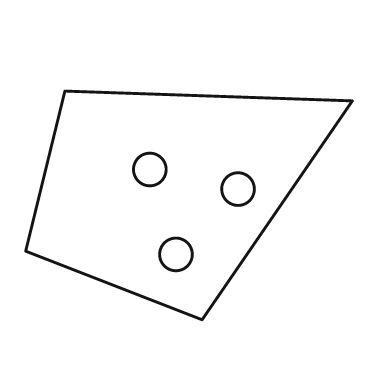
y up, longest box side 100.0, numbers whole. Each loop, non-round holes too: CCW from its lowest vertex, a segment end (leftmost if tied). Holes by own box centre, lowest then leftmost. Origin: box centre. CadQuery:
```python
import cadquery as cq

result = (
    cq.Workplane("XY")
    .moveTo(4.0, -35.0)
    .lineTo(50.0, 32.0)
    .lineTo(-38.0, 35.0)
    .lineTo(-50.0, -14.0)
    .close()
    .moveTo(-4.0, -15.0)
    .circle(5.0)
    .moveTo(15.0, 5.0)
    .circle(5.0)
    .moveTo(-12.0, 11.0)
    .circle(5.0)
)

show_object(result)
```